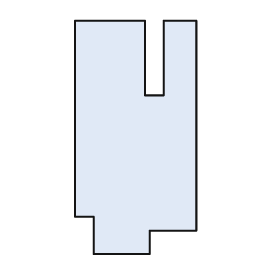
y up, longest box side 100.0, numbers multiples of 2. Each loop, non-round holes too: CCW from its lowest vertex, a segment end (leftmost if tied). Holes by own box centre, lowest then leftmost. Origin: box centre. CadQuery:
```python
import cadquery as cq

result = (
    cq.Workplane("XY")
    .moveTo(-18.0, -50.0)
    .lineTo(6.0, -50.0)
    .lineTo(6.0, -40.0)
    .lineTo(26.0, -40.0)
    .lineTo(26.0, 50.0)
    .lineTo(12.0, 50.0)
    .lineTo(12.0, 18.0)
    .lineTo(4.0, 18.0)
    .lineTo(4.0, 50.0)
    .lineTo(-26.0, 50.0)
    .lineTo(-26.0, -34.0)
    .lineTo(-18.0, -34.0)
    .close()
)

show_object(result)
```